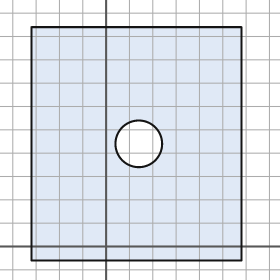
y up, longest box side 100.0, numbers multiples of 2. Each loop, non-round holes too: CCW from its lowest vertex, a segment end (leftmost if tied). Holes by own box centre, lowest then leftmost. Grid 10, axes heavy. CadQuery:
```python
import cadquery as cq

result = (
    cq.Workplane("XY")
    .moveTo(-32.0, -6.0)
    .lineTo(58.0, -6.0)
    .lineTo(58.0, 94.0)
    .lineTo(-32.0, 94.0)
    .close()
    .moveTo(14.0, 44.0)
    .circle(10.0)
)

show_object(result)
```